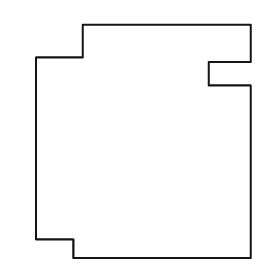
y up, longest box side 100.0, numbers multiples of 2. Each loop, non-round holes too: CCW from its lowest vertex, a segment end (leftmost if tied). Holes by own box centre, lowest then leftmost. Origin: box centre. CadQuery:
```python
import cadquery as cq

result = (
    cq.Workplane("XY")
    .moveTo(-30.0, -50.0)
    .lineTo(46.0, -50.0)
    .lineTo(46.0, 24.0)
    .lineTo(28.0, 24.0)
    .lineTo(28.0, 34.0)
    .lineTo(46.0, 34.0)
    .lineTo(46.0, 50.0)
    .lineTo(-26.0, 50.0)
    .lineTo(-26.0, 36.0)
    .lineTo(-46.0, 36.0)
    .lineTo(-46.0, -42.0)
    .lineTo(-30.0, -42.0)
    .close()
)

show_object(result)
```